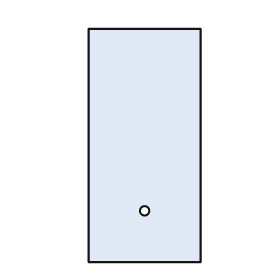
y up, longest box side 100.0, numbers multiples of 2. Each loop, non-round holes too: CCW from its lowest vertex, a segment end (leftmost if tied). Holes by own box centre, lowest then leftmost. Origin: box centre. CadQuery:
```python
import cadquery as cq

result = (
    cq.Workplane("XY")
    .moveTo(-24.0, -50.0)
    .lineTo(24.0, -50.0)
    .lineTo(24.0, 50.0)
    .lineTo(-24.0, 50.0)
    .close()
    .moveTo(0.0, -28.0)
    .circle(2.0)
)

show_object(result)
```